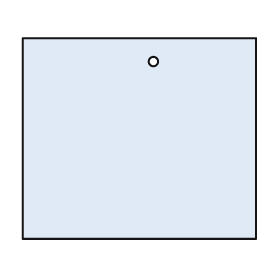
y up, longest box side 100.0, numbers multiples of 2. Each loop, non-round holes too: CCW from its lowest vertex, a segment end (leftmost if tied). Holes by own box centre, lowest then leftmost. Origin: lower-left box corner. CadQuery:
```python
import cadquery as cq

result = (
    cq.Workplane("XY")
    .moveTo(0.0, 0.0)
    .lineTo(100.0, 0.0)
    .lineTo(100.0, 86.0)
    .lineTo(0.0, 86.0)
    .close()
    .moveTo(56.0, 76.0)
    .circle(2.0)
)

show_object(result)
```